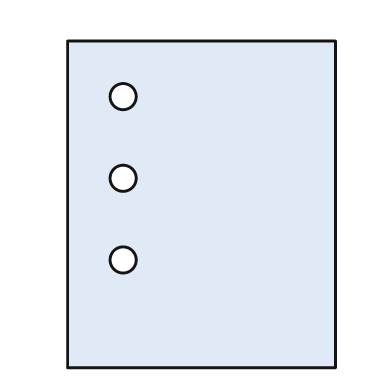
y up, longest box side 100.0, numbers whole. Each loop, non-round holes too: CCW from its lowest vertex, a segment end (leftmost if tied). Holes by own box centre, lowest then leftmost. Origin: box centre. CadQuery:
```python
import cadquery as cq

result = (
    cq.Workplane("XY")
    .moveTo(-41.0, -50.0)
    .lineTo(41.0, -50.0)
    .lineTo(41.0, 50.0)
    .lineTo(-41.0, 50.0)
    .close()
    .moveTo(-24.0, -17.0)
    .circle(4.0)
    .moveTo(-24.0, 8.0)
    .circle(4.0)
    .moveTo(-24.0, 33.0)
    .circle(4.0)
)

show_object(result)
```